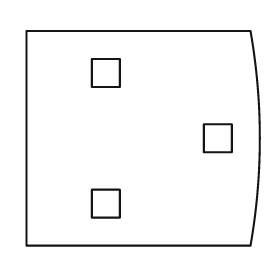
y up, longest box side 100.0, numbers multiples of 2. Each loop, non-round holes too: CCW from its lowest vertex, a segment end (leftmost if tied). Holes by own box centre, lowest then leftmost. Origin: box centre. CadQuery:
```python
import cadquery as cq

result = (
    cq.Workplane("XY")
    .moveTo(-50.0, -46.0)
    .lineTo(46.0, -46.0)
    .threePointArc((50.0, 0.0), (46.0, 46.0))
    .lineTo(-50.0, 46.0)
    .close()
    .moveTo(-22.0, -34.0)
    .lineTo(-10.0, -34.0)
    .lineTo(-10.0, -22.0)
    .lineTo(-22.0, -22.0)
    .close()
    .moveTo(26.0, -6.0)
    .lineTo(38.0, -6.0)
    .lineTo(38.0, 6.0)
    .lineTo(26.0, 6.0)
    .close()
    .moveTo(-22.0, 22.0)
    .lineTo(-10.0, 22.0)
    .lineTo(-10.0, 34.0)
    .lineTo(-22.0, 34.0)
    .close()
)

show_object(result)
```